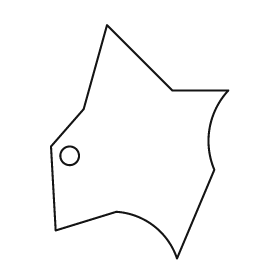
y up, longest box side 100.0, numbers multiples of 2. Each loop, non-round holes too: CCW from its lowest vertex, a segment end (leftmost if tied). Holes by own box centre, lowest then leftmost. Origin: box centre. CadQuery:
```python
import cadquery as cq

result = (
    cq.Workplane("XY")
    .moveTo(16.0, -50.0)
    .lineTo(32.0, -12.0)
    .threePointArc((30.0, 6.0), (38.0, 22.0))
    .lineTo(14.0, 22.0)
    .lineTo(-14.0, 50.0)
    .lineTo(-24.0, 14.0)
    .lineTo(-38.0, -2.0)
    .lineTo(-36.0, -38.0)
    .lineTo(-10.0, -30.0)
    .threePointArc((6.0, -36.0), (16.0, -50.0))
    .close()
    .moveTo(-30.0, -6.0)
    .circle(4.0)
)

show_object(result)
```